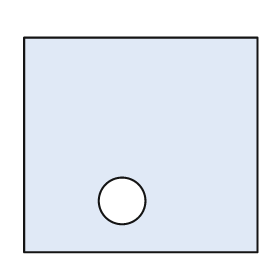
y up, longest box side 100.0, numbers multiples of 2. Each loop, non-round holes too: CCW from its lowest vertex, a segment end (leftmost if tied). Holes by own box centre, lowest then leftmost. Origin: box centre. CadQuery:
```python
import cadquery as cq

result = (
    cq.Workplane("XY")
    .moveTo(-50.0, -46.0)
    .lineTo(50.0, -46.0)
    .lineTo(50.0, 46.0)
    .lineTo(-50.0, 46.0)
    .close()
    .moveTo(-8.0, -24.0)
    .circle(10.0)
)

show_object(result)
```